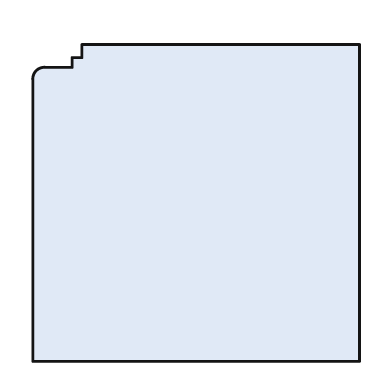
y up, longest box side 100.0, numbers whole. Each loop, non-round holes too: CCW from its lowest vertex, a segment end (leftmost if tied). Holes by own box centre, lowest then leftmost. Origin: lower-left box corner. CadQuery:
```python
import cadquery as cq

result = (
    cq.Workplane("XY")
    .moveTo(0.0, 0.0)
    .lineTo(100.0, 0.0)
    .lineTo(100.0, 97.0)
    .lineTo(15.0, 97.0)
    .lineTo(15.0, 93.0)
    .lineTo(12.0, 93.0)
    .lineTo(12.0, 90.0)
    .lineTo(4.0, 90.0)
    .threePointArc((1.0, 89.0), (0.0, 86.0))
    .close()
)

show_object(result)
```